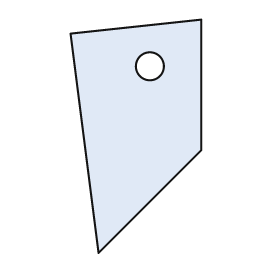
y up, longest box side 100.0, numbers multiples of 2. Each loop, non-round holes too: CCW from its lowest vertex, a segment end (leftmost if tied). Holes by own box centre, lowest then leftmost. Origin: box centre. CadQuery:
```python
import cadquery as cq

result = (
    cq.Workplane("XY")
    .moveTo(-16.0, -50.0)
    .lineTo(28.0, -6.0)
    .lineTo(28.0, 50.0)
    .lineTo(-28.0, 44.0)
    .close()
    .moveTo(6.0, 30.0)
    .circle(6.0)
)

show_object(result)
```